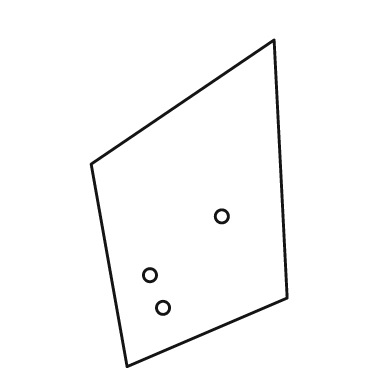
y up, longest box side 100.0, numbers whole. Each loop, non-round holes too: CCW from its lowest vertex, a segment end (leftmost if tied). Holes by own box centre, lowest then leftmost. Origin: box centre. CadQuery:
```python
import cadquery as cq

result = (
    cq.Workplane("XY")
    .moveTo(-19.0, -50.0)
    .lineTo(30.0, -29.0)
    .lineTo(26.0, 50.0)
    .lineTo(-30.0, 12.0)
    .close()
    .moveTo(-8.0, -32.0)
    .circle(2.0)
    .moveTo(-12.0, -22.0)
    .circle(2.0)
    .moveTo(10.0, -4.0)
    .circle(2.0)
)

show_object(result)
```